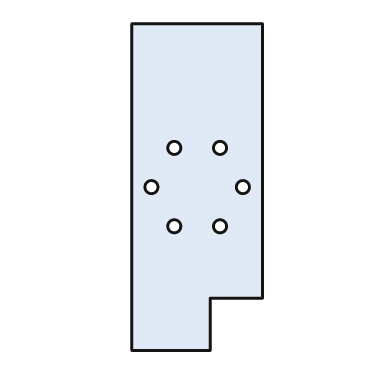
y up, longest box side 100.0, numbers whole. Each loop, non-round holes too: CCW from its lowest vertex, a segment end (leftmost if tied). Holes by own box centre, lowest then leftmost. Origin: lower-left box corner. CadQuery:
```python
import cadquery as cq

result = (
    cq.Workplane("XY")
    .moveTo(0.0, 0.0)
    .lineTo(24.0, 0.0)
    .lineTo(24.0, 16.0)
    .lineTo(40.0, 16.0)
    .lineTo(40.0, 100.0)
    .lineTo(0.0, 100.0)
    .close()
    .moveTo(13.0, 38.0)
    .circle(2.0)
    .moveTo(27.0, 38.0)
    .circle(2.0)
    .moveTo(6.0, 50.0)
    .circle(2.0)
    .moveTo(34.0, 50.0)
    .circle(2.0)
    .moveTo(13.0, 62.0)
    .circle(2.0)
    .moveTo(27.0, 62.0)
    .circle(2.0)
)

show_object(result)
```